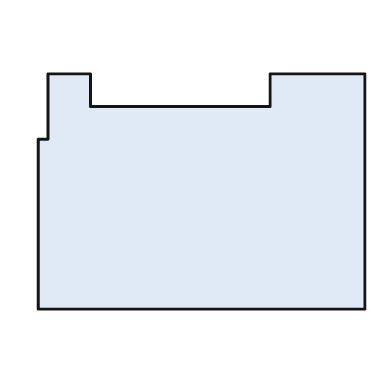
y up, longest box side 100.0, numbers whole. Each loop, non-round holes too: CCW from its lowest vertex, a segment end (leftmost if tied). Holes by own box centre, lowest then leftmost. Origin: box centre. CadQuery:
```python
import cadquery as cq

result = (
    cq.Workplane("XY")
    .moveTo(-50.0, -36.0)
    .lineTo(50.0, -36.0)
    .lineTo(50.0, 36.0)
    .lineTo(21.0, 36.0)
    .lineTo(21.0, 26.0)
    .lineTo(-34.0, 26.0)
    .lineTo(-34.0, 36.0)
    .lineTo(-47.0, 36.0)
    .lineTo(-47.0, 16.0)
    .lineTo(-50.0, 16.0)
    .close()
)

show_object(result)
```